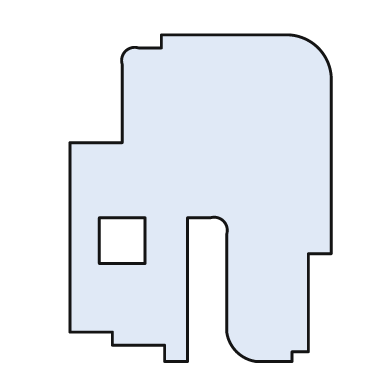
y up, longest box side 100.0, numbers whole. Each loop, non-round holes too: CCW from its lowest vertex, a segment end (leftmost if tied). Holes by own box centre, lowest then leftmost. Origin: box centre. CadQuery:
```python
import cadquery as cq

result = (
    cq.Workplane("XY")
    .moveTo(-11.0, -50.0)
    .lineTo(-4.0, -50.0)
    .lineTo(-4.0, -6.0)
    .lineTo(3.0, -6.0)
    .threePointArc((7.0, -7.0), (8.0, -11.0))
    .lineTo(8.0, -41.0)
    .threePointArc((11.0, -47.0), (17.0, -50.0))
    .lineTo(28.0, -50.0)
    .lineTo(28.0, -47.0)
    .lineTo(33.0, -47.0)
    .lineTo(33.0, -17.0)
    .lineTo(40.0, -17.0)
    .lineTo(40.0, 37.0)
    .threePointArc((36.0, 46.0), (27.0, 50.0))
    .lineTo(-12.0, 50.0)
    .lineTo(-12.0, 46.0)
    .lineTo(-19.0, 46.0)
    .threePointArc((-23.0, 45.0), (-24.0, 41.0))
    .lineTo(-24.0, 17.0)
    .lineTo(-40.0, 17.0)
    .lineTo(-40.0, -41.0)
    .lineTo(-27.0, -41.0)
    .lineTo(-27.0, -45.0)
    .lineTo(-11.0, -45.0)
    .close()
    .moveTo(-31.0, -20.0)
    .lineTo(-17.0, -20.0)
    .lineTo(-17.0, -6.0)
    .lineTo(-31.0, -6.0)
    .close()
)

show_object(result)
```